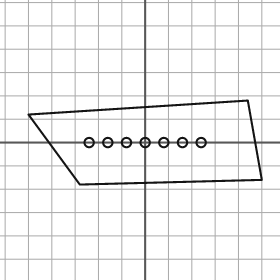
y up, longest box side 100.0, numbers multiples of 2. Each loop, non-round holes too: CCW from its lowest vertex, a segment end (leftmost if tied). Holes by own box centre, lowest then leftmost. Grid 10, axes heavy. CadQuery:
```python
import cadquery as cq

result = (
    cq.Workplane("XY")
    .moveTo(-28.0, -18.0)
    .lineTo(50.0, -16.0)
    .lineTo(44.0, 18.0)
    .lineTo(-50.0, 12.0)
    .close()
    .moveTo(-24.0, 0.0)
    .circle(2.0)
    .moveTo(-16.0, 0.0)
    .circle(2.0)
    .moveTo(-8.0, 0.0)
    .circle(2.0)
    .moveTo(0.0, 0.0)
    .circle(2.0)
    .moveTo(8.0, 0.0)
    .circle(2.0)
    .moveTo(16.0, 0.0)
    .circle(2.0)
    .moveTo(24.0, 0.0)
    .circle(2.0)
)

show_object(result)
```